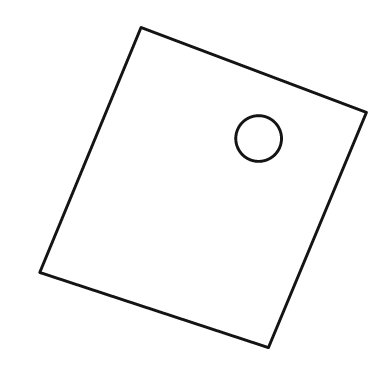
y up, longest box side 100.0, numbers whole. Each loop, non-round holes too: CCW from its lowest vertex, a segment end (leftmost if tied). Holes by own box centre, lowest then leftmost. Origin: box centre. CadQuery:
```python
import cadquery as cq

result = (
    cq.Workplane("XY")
    .moveTo(20.0, -49.0)
    .lineTo(50.0, 23.0)
    .lineTo(-19.0, 49.0)
    .lineTo(-50.0, -26.0)
    .close()
    .moveTo(17.0, 15.0)
    .circle(7.0)
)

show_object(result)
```